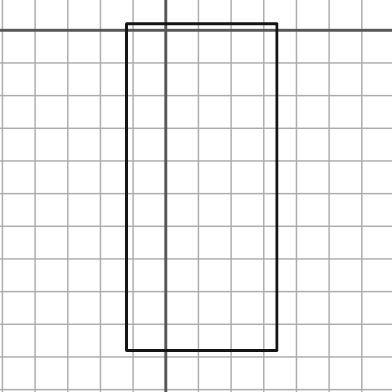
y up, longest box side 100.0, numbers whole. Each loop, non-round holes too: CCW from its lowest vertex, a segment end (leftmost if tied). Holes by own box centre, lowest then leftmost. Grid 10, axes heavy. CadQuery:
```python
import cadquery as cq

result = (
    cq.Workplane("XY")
    .moveTo(-12.0, -98.0)
    .lineTo(34.0, -98.0)
    .lineTo(34.0, 2.0)
    .lineTo(-12.0, 2.0)
    .close()
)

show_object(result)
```